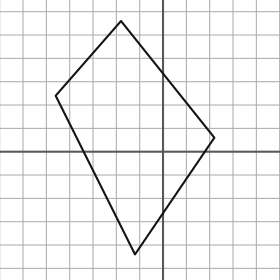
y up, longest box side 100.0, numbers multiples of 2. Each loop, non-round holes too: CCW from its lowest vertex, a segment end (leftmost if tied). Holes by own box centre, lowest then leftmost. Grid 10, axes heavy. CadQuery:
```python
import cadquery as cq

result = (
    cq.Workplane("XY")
    .moveTo(-12.0, -44.0)
    .lineTo(22.0, 6.0)
    .lineTo(-18.0, 56.0)
    .lineTo(-46.0, 24.0)
    .close()
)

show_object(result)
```